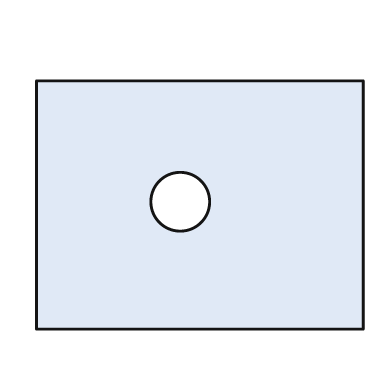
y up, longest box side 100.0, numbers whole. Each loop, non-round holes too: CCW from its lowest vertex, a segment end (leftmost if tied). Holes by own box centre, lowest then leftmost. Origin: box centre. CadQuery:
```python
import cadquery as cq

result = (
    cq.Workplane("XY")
    .moveTo(-50.0, -38.0)
    .lineTo(50.0, -38.0)
    .lineTo(50.0, 38.0)
    .lineTo(-50.0, 38.0)
    .close()
    .moveTo(-6.0, 1.0)
    .circle(9.0)
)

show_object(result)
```